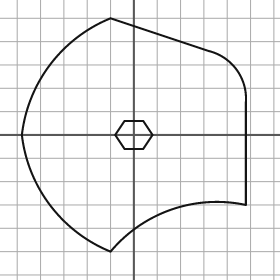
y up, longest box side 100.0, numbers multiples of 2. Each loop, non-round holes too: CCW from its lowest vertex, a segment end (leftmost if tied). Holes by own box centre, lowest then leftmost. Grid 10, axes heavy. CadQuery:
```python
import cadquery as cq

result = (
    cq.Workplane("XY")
    .moveTo(-10.0, -50.0)
    .threePointArc((16.0, -32.0), (48.0, -30.0))
    .lineTo(48.0, 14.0)
    .threePointArc((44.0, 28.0), (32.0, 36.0))
    .lineTo(-10.0, 50.0)
    .threePointArc((-36.0, 30.0), (-48.0, 0.0))
    .threePointArc((-36.0, -30.0), (-10.0, -50.0))
    .close()
    .moveTo(-4.0, -6.0)
    .lineTo(4.0, -6.0)
    .lineTo(8.0, 0.0)
    .lineTo(4.0, 6.0)
    .lineTo(-4.0, 6.0)
    .lineTo(-8.0, 0.0)
    .close()
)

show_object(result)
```